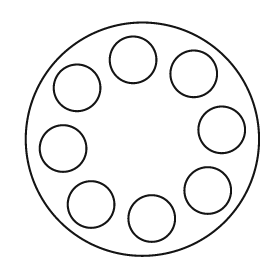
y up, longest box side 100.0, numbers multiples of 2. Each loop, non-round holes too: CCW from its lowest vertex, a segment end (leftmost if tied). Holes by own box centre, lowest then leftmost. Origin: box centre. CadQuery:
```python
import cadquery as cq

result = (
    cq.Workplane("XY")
    .moveTo(0.0, 0.0)
    .circle(50.0)
    .moveTo(4.0, -34.0)
    .circle(10.0)
    .moveTo(-22.0, -28.0)
    .circle(10.0)
    .moveTo(28.0, -22.0)
    .circle(10.0)
    .moveTo(-34.0, -4.0)
    .circle(10.0)
    .moveTo(34.0, 4.0)
    .circle(10.0)
    .moveTo(-28.0, 22.0)
    .circle(10.0)
    .moveTo(22.0, 28.0)
    .circle(10.0)
    .moveTo(-4.0, 34.0)
    .circle(10.0)
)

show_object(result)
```